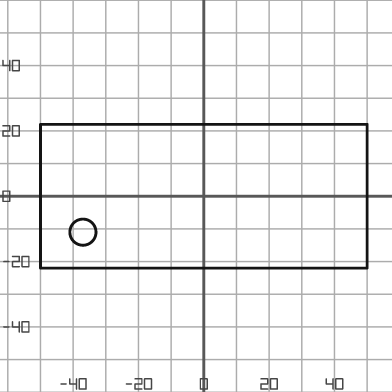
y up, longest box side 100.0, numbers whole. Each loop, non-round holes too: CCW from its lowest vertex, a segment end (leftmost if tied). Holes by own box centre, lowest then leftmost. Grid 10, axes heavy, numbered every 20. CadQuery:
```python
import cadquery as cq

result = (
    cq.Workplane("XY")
    .moveTo(-50.0, -22.0)
    .lineTo(50.0, -22.0)
    .lineTo(50.0, 22.0)
    .lineTo(-50.0, 22.0)
    .close()
    .moveTo(-37.0, -11.0)
    .circle(4.0)
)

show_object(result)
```